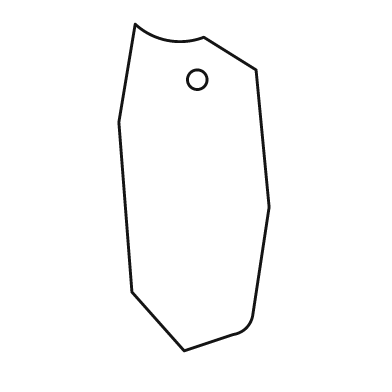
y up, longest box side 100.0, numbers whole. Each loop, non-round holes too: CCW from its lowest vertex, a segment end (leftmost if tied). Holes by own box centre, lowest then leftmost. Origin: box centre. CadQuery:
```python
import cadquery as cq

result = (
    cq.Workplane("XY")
    .moveTo(-3.0, -50.0)
    .lineTo(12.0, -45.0)
    .threePointArc((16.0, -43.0), (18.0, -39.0))
    .lineTo(23.0, -6.0)
    .lineTo(19.0, 36.0)
    .lineTo(3.0, 46.0)
    .threePointArc((-8.0, 45.0), (-18.0, 50.0))
    .lineTo(-23.0, 20.0)
    .lineTo(-19.0, -32.0)
    .close()
    .moveTo(1.0, 33.0)
    .circle(3.0)
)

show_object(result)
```